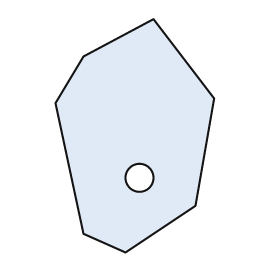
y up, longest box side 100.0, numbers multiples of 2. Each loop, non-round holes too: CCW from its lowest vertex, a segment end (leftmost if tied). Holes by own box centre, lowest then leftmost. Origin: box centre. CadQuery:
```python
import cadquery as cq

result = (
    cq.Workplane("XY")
    .moveTo(-4.0, -50.0)
    .lineTo(26.0, -30.0)
    .lineTo(34.0, 16.0)
    .lineTo(8.0, 50.0)
    .lineTo(-22.0, 34.0)
    .lineTo(-34.0, 14.0)
    .lineTo(-22.0, -42.0)
    .close()
    .moveTo(2.0, -18.0)
    .circle(6.0)
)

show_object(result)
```